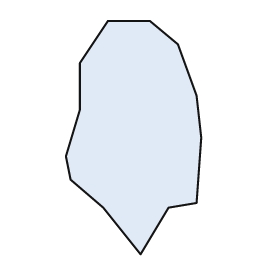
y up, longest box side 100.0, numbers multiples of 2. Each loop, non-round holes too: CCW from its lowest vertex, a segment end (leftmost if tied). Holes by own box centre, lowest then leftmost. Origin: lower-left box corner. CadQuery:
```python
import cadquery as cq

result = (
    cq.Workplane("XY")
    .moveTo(32.0, 0.0)
    .lineTo(44.0, 20.0)
    .lineTo(56.0, 22.0)
    .lineTo(58.0, 50.0)
    .lineTo(56.0, 68.0)
    .lineTo(48.0, 90.0)
    .lineTo(36.0, 100.0)
    .lineTo(18.0, 100.0)
    .lineTo(6.0, 82.0)
    .lineTo(6.0, 62.0)
    .lineTo(0.0, 42.0)
    .lineTo(2.0, 32.0)
    .lineTo(16.0, 20.0)
    .close()
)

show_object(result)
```